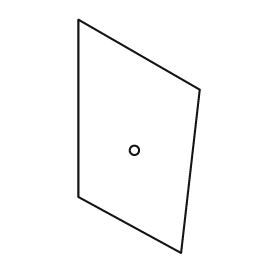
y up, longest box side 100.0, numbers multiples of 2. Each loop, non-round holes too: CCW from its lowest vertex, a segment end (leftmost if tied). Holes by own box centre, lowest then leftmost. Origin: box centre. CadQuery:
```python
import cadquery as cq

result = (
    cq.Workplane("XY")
    .moveTo(18.0, -50.0)
    .lineTo(26.0, 20.0)
    .lineTo(-26.0, 50.0)
    .lineTo(-26.0, -26.0)
    .close()
    .moveTo(-2.0, -6.0)
    .circle(2.0)
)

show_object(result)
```